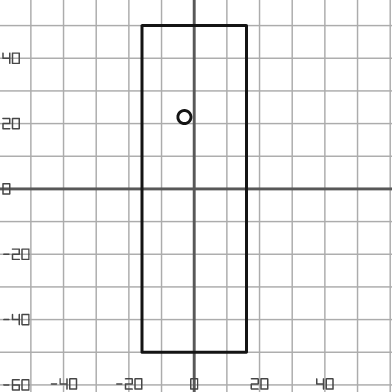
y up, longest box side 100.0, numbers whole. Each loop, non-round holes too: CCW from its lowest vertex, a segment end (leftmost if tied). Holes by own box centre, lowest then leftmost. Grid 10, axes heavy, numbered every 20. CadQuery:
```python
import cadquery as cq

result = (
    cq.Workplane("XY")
    .moveTo(-16.0, -50.0)
    .lineTo(16.0, -50.0)
    .lineTo(16.0, 50.0)
    .lineTo(-16.0, 50.0)
    .close()
    .moveTo(-3.0, 22.0)
    .circle(2.0)
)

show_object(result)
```